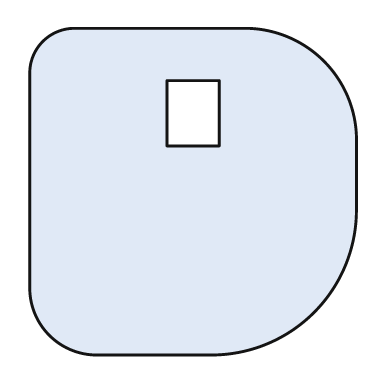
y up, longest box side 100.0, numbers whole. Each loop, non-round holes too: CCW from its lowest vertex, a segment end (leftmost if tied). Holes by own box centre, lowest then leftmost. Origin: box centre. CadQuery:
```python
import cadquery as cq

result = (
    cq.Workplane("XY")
    .moveTo(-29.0, -50.0)
    .lineTo(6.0, -50.0)
    .threePointArc((37.0, -37.0), (50.0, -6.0))
    .lineTo(50.0, 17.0)
    .threePointArc((40.0, 40.0), (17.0, 50.0))
    .lineTo(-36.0, 50.0)
    .threePointArc((-46.0, 46.0), (-50.0, 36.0))
    .lineTo(-50.0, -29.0)
    .threePointArc((-44.0, -44.0), (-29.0, -50.0))
    .close()
    .moveTo(-8.0, 14.0)
    .lineTo(8.0, 14.0)
    .lineTo(8.0, 34.0)
    .lineTo(-8.0, 34.0)
    .close()
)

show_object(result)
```